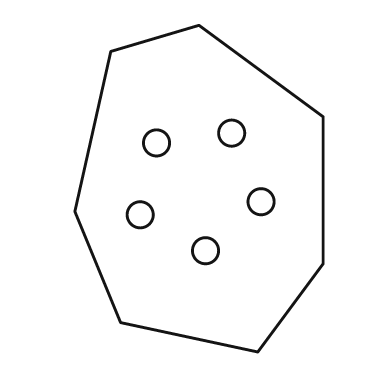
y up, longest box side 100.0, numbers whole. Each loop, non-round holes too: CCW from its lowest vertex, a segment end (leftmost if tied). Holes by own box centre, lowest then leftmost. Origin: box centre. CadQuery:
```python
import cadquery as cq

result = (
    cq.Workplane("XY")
    .moveTo(18.0, -50.0)
    .lineTo(38.0, -23.0)
    .lineTo(38.0, 22.0)
    .lineTo(0.0, 50.0)
    .lineTo(-27.0, 42.0)
    .lineTo(-38.0, -7.0)
    .lineTo(-24.0, -41.0)
    .close()
    .moveTo(2.0, -19.0)
    .circle(4.0)
    .moveTo(-18.0, -8.0)
    .circle(4.0)
    .moveTo(19.0, -4.0)
    .circle(4.0)
    .moveTo(-13.0, 14.0)
    .circle(4.0)
    .moveTo(10.0, 17.0)
    .circle(4.0)
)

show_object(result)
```